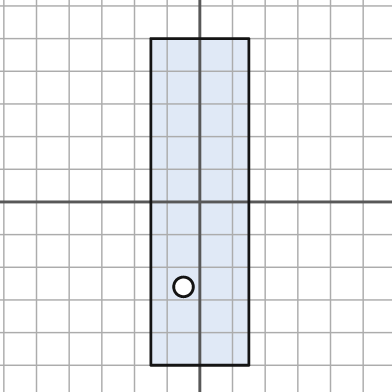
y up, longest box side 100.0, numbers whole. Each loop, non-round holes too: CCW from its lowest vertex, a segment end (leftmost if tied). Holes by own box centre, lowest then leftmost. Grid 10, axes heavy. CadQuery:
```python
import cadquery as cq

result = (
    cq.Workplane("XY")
    .moveTo(-15.0, -50.0)
    .lineTo(15.0, -50.0)
    .lineTo(15.0, 50.0)
    .lineTo(-15.0, 50.0)
    .close()
    .moveTo(-5.0, -26.0)
    .circle(3.0)
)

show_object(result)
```